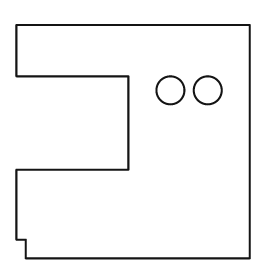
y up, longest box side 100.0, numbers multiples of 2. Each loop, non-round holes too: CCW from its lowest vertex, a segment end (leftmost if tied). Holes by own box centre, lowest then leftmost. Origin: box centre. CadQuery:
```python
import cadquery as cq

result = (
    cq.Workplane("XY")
    .moveTo(-46.0, -50.0)
    .lineTo(50.0, -50.0)
    .lineTo(50.0, 50.0)
    .lineTo(-50.0, 50.0)
    .lineTo(-50.0, 28.0)
    .lineTo(-2.0, 28.0)
    .lineTo(-2.0, -12.0)
    .lineTo(-50.0, -12.0)
    .lineTo(-50.0, -42.0)
    .lineTo(-46.0, -42.0)
    .close()
    .moveTo(16.0, 22.0)
    .circle(6.0)
    .moveTo(32.0, 22.0)
    .circle(6.0)
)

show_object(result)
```